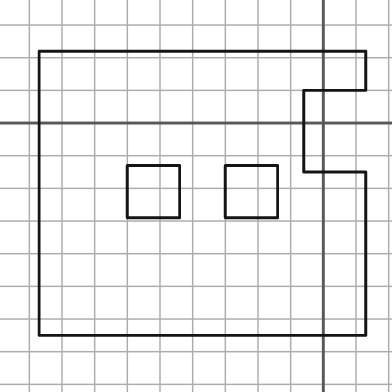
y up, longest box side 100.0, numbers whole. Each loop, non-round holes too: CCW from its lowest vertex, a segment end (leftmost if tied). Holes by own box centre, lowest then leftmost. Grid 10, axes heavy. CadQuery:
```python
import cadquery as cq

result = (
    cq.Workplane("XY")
    .moveTo(-87.0, -65.0)
    .lineTo(13.0, -65.0)
    .lineTo(13.0, -15.0)
    .lineTo(-6.0, -15.0)
    .lineTo(-6.0, 10.0)
    .lineTo(13.0, 10.0)
    .lineTo(13.0, 22.0)
    .lineTo(-87.0, 22.0)
    .close()
    .moveTo(-60.0, -29.0)
    .lineTo(-44.0, -29.0)
    .lineTo(-44.0, -13.0)
    .lineTo(-60.0, -13.0)
    .close()
    .moveTo(-30.0, -29.0)
    .lineTo(-14.0, -29.0)
    .lineTo(-14.0, -13.0)
    .lineTo(-30.0, -13.0)
    .close()
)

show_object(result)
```